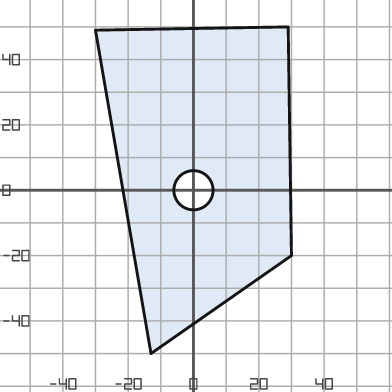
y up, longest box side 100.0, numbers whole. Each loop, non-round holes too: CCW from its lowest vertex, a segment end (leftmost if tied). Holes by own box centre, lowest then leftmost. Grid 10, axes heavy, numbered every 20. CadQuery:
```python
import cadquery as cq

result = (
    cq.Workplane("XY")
    .moveTo(-13.0, -50.0)
    .lineTo(30.0, -20.0)
    .lineTo(29.0, 50.0)
    .lineTo(-30.0, 49.0)
    .close()
    .moveTo(0.0, 0.0)
    .circle(6.0)
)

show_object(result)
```